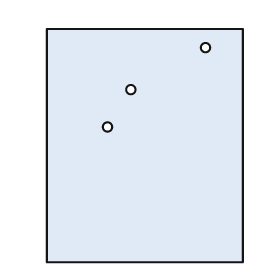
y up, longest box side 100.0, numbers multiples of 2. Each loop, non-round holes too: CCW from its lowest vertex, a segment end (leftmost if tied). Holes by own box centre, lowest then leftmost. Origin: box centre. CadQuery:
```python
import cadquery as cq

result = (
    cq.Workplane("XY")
    .moveTo(-42.0, -50.0)
    .lineTo(42.0, -50.0)
    .lineTo(42.0, 50.0)
    .lineTo(-42.0, 50.0)
    .close()
    .moveTo(-16.0, 8.0)
    .circle(2.0)
    .moveTo(-6.0, 24.0)
    .circle(2.0)
    .moveTo(26.0, 42.0)
    .circle(2.0)
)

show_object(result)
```